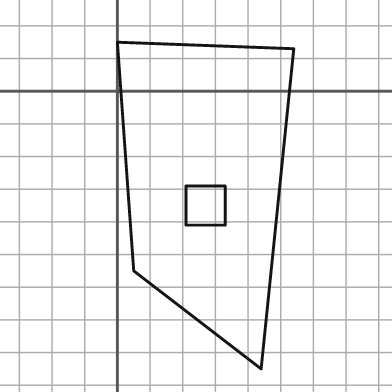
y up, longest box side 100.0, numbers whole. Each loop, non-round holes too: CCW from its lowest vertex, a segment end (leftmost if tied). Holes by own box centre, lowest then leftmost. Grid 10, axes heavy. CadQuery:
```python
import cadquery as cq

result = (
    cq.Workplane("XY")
    .moveTo(44.0, -85.0)
    .lineTo(54.0, 13.0)
    .lineTo(0.0, 15.0)
    .lineTo(5.0, -55.0)
    .close()
    .moveTo(21.0, -41.0)
    .lineTo(33.0, -41.0)
    .lineTo(33.0, -29.0)
    .lineTo(21.0, -29.0)
    .close()
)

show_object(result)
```